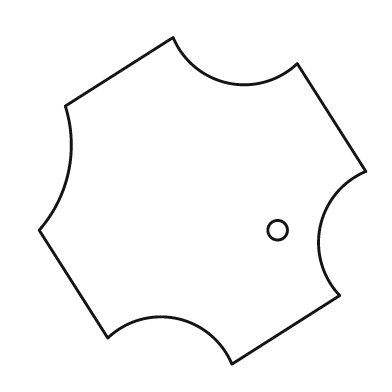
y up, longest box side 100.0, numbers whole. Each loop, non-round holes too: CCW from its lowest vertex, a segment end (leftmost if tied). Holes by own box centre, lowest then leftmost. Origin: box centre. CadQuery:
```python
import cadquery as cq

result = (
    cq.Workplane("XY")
    .moveTo(9.0, -50.0)
    .lineTo(42.0, -29.0)
    .threePointArc((36.0, -8.0), (50.0, 9.0))
    .lineTo(29.0, 42.0)
    .threePointArc((8.0, 36.0), (-9.0, 50.0))
    .lineTo(-42.0, 29.0)
    .threePointArc((-41.0, 9.0), (-50.0, -9.0))
    .lineTo(-29.0, -42.0)
    .threePointArc((-8.0, -36.0), (9.0, -50.0))
    .close()
    .moveTo(23.0, -9.0)
    .circle(3.0)
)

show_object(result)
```